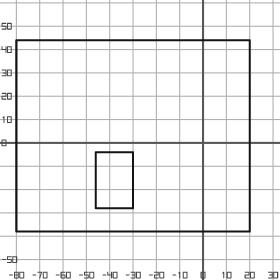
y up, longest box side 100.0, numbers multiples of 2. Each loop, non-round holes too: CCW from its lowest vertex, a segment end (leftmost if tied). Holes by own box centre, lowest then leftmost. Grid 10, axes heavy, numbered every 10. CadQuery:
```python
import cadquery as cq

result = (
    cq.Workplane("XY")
    .moveTo(-80.0, -38.0)
    .lineTo(20.0, -38.0)
    .lineTo(20.0, 44.0)
    .lineTo(-80.0, 44.0)
    .close()
    .moveTo(-46.0, -28.0)
    .lineTo(-30.0, -28.0)
    .lineTo(-30.0, -4.0)
    .lineTo(-46.0, -4.0)
    .close()
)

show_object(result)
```